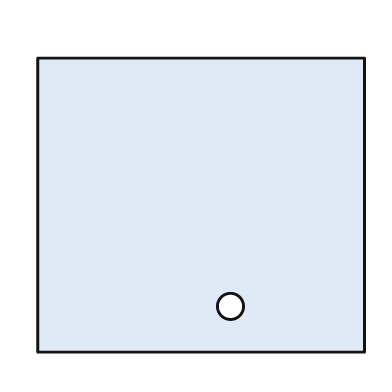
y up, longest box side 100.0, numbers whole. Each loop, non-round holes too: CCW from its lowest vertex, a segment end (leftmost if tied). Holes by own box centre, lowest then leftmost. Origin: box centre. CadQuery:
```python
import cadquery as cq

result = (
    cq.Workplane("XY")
    .moveTo(-50.0, -45.0)
    .lineTo(50.0, -45.0)
    .lineTo(50.0, 45.0)
    .lineTo(-50.0, 45.0)
    .close()
    .moveTo(9.0, -31.0)
    .circle(4.0)
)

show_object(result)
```